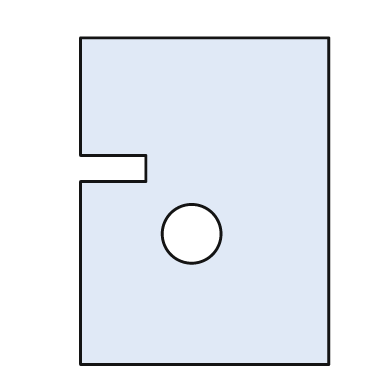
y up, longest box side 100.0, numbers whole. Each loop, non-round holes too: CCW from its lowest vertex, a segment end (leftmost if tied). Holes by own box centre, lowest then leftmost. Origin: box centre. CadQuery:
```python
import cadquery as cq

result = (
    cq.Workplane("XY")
    .moveTo(-38.0, -50.0)
    .lineTo(38.0, -50.0)
    .lineTo(38.0, 50.0)
    .lineTo(-38.0, 50.0)
    .lineTo(-38.0, 14.0)
    .lineTo(-18.0, 14.0)
    .lineTo(-18.0, 6.0)
    .lineTo(-38.0, 6.0)
    .close()
    .moveTo(-4.0, -10.0)
    .circle(9.0)
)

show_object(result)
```